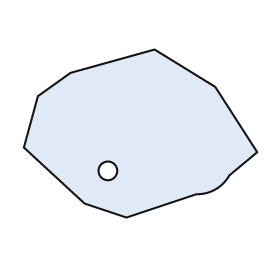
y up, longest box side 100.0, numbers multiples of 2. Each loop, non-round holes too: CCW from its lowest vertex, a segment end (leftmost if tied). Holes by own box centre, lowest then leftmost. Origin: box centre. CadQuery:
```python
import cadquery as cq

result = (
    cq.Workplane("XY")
    .moveTo(-6.0, -36.0)
    .lineTo(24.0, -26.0)
    .threePointArc((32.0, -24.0), (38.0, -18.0))
    .lineTo(50.0, -8.0)
    .lineTo(32.0, 20.0)
    .lineTo(6.0, 36.0)
    .lineTo(-30.0, 26.0)
    .lineTo(-44.0, 16.0)
    .lineTo(-50.0, -6.0)
    .lineTo(-24.0, -30.0)
    .close()
    .moveTo(-14.0, -16.0)
    .circle(4.0)
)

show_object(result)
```